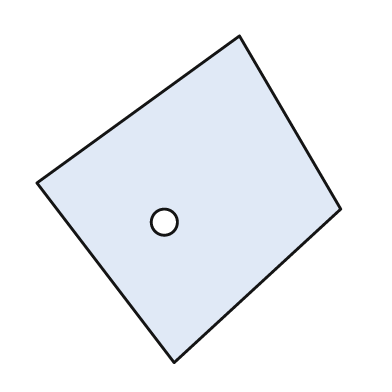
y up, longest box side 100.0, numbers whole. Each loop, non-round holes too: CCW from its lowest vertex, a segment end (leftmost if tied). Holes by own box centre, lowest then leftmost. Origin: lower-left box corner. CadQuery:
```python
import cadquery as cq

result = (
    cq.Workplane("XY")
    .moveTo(42.0, 0.0)
    .lineTo(93.0, 47.0)
    .lineTo(62.0, 100.0)
    .lineTo(0.0, 55.0)
    .close()
    .moveTo(39.0, 43.0)
    .circle(4.0)
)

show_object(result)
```